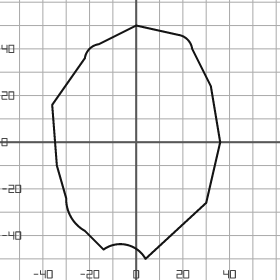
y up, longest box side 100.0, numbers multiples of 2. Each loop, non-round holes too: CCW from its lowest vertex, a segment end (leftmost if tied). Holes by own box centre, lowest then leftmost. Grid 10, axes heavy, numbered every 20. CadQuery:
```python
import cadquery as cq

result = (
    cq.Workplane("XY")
    .moveTo(4.0, -50.0)
    .lineTo(30.0, -26.0)
    .lineTo(36.0, 0.0)
    .lineTo(32.0, 24.0)
    .lineTo(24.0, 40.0)
    .threePointArc((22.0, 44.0), (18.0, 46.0))
    .lineTo(0.0, 50.0)
    .lineTo(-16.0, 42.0)
    .threePointArc((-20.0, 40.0), (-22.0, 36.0))
    .lineTo(-36.0, 16.0)
    .lineTo(-34.0, -10.0)
    .lineTo(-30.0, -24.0)
    .threePointArc((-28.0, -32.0), (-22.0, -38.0))
    .lineTo(-14.0, -46.0)
    .threePointArc((-4.0, -44.0), (4.0, -50.0))
    .close()
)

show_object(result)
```